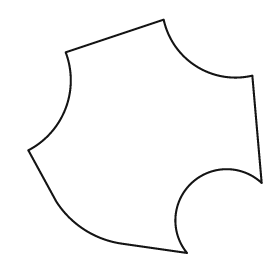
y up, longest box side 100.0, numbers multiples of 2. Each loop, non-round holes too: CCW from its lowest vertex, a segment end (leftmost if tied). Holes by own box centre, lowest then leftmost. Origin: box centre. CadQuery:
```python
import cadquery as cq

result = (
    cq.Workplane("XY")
    .moveTo(18.0, -50.0)
    .threePointArc((20.0, -20.0), (50.0, -20.0))
    .lineTo(46.0, 26.0)
    .threePointArc((22.0, 30.0), (8.0, 50.0))
    .lineTo(-34.0, 36.0)
    .threePointArc((-34.0, 12.0), (-50.0, -6.0))
    .lineTo(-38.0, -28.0)
    .threePointArc((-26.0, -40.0), (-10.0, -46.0))
    .close()
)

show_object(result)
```